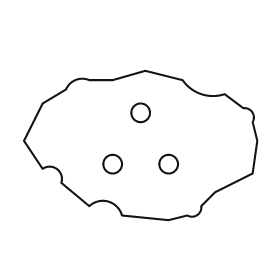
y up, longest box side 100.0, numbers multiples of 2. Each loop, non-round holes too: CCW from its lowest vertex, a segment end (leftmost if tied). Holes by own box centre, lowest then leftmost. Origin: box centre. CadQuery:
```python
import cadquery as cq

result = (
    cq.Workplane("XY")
    .moveTo(12.0, -32.0)
    .lineTo(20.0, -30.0)
    .threePointArc((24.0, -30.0), (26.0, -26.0))
    .lineTo(32.0, -20.0)
    .lineTo(48.0, -12.0)
    .lineTo(50.0, 2.0)
    .lineTo(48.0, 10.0)
    .threePointArc((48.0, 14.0), (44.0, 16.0))
    .lineTo(36.0, 22.0)
    .threePointArc((26.0, 22.0), (18.0, 28.0))
    .lineTo(2.0, 32.0)
    .lineTo(-12.0, 28.0)
    .lineTo(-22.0, 28.0)
    .threePointArc((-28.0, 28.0), (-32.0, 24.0))
    .lineTo(-42.0, 18.0)
    .lineTo(-50.0, 2.0)
    .lineTo(-42.0, -10.0)
    .threePointArc((-36.0, -10.0), (-34.0, -16.0))
    .lineTo(-22.0, -26.0)
    .threePointArc((-14.0, -24.0), (-8.0, -30.0))
    .close()
    .moveTo(-12.0, -8.0)
    .circle(4.0)
    .moveTo(12.0, -8.0)
    .circle(4.0)
    .moveTo(0.0, 14.0)
    .circle(4.0)
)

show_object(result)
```